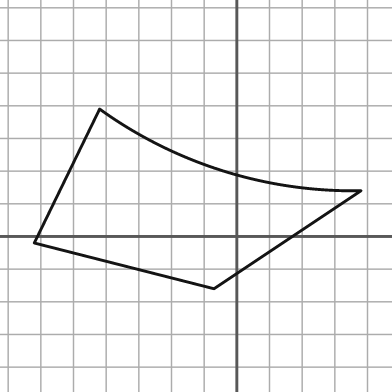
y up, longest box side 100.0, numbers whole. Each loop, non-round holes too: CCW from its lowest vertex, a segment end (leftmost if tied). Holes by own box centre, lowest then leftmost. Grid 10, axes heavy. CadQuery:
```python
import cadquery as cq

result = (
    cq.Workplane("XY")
    .moveTo(-7.0, -16.0)
    .lineTo(38.0, 14.0)
    .threePointArc((-4.0, 20.0), (-42.0, 39.0))
    .lineTo(-62.0, -2.0)
    .close()
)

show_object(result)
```